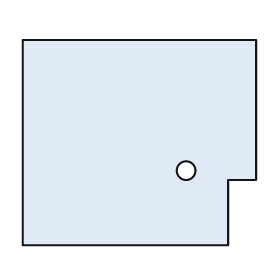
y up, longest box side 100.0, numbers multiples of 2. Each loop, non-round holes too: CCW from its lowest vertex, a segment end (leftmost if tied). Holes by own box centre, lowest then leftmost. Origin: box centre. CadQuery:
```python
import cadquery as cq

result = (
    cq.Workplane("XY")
    .moveTo(-50.0, -44.0)
    .lineTo(38.0, -44.0)
    .lineTo(38.0, -16.0)
    .lineTo(50.0, -16.0)
    .lineTo(50.0, 44.0)
    .lineTo(-50.0, 44.0)
    .close()
    .moveTo(20.0, -12.0)
    .circle(4.0)
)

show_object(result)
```